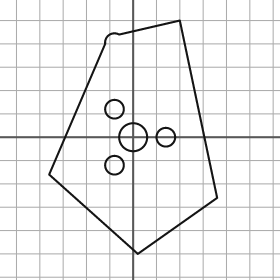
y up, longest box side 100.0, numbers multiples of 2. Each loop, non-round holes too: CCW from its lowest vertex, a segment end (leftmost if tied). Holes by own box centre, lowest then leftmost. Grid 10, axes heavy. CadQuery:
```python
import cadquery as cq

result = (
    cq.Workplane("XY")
    .moveTo(2.0, -50.0)
    .lineTo(36.0, -26.0)
    .lineTo(20.0, 50.0)
    .lineTo(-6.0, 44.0)
    .threePointArc((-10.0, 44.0), (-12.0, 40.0))
    .lineTo(-36.0, -16.0)
    .close()
    .moveTo(-8.0, -12.0)
    .circle(4.0)
    .moveTo(0.0, 0.0)
    .circle(6.0)
    .moveTo(14.0, 0.0)
    .circle(4.0)
    .moveTo(-8.0, 12.0)
    .circle(4.0)
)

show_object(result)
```